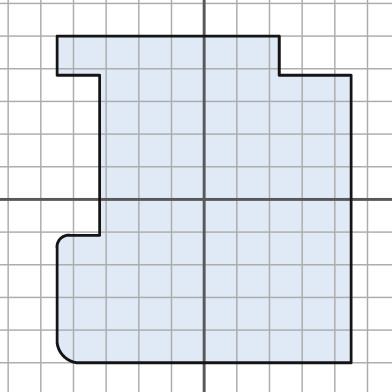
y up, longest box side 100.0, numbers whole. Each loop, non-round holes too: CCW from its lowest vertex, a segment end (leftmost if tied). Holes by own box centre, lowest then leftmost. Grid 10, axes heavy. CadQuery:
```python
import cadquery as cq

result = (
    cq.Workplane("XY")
    .moveTo(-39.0, -50.0)
    .lineTo(45.0, -50.0)
    .lineTo(45.0, 38.0)
    .lineTo(23.0, 38.0)
    .lineTo(23.0, 50.0)
    .lineTo(-45.0, 50.0)
    .lineTo(-45.0, 38.0)
    .lineTo(-32.0, 38.0)
    .lineTo(-32.0, -11.0)
    .lineTo(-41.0, -11.0)
    .threePointArc((-44.0, -12.0), (-45.0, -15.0))
    .lineTo(-45.0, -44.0)
    .threePointArc((-43.0, -48.0), (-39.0, -50.0))
    .close()
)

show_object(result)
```